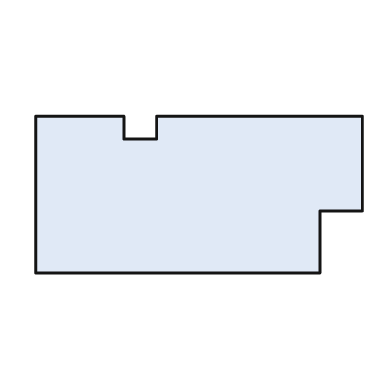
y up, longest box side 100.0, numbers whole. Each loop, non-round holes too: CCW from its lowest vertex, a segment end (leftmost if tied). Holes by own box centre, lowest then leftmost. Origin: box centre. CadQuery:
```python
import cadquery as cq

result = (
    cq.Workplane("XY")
    .moveTo(-50.0, -24.0)
    .lineTo(37.0, -24.0)
    .lineTo(37.0, -5.0)
    .lineTo(50.0, -5.0)
    .lineTo(50.0, 24.0)
    .lineTo(-13.0, 24.0)
    .lineTo(-13.0, 17.0)
    .lineTo(-23.0, 17.0)
    .lineTo(-23.0, 24.0)
    .lineTo(-50.0, 24.0)
    .close()
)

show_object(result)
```